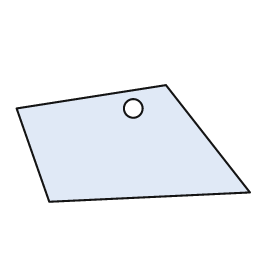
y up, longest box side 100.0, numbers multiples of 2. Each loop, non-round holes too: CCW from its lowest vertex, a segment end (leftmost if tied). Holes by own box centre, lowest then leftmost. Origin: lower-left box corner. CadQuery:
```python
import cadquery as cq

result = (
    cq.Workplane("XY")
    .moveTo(14.0, 0.0)
    .lineTo(100.0, 4.0)
    .lineTo(64.0, 50.0)
    .lineTo(0.0, 40.0)
    .close()
    .moveTo(50.0, 40.0)
    .circle(4.0)
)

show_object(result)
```